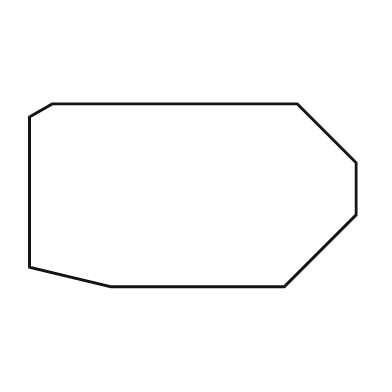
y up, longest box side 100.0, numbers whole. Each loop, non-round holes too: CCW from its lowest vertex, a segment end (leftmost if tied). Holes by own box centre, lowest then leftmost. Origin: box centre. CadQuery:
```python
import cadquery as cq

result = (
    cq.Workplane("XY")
    .moveTo(-25.0, -28.0)
    .lineTo(28.0, -28.0)
    .lineTo(50.0, -6.0)
    .lineTo(50.0, 10.0)
    .lineTo(32.0, 28.0)
    .lineTo(-43.0, 28.0)
    .lineTo(-50.0, 24.0)
    .lineTo(-50.0, -22.0)
    .close()
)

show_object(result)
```